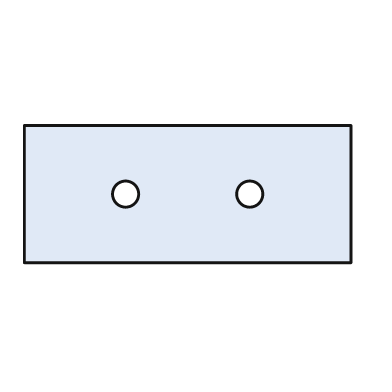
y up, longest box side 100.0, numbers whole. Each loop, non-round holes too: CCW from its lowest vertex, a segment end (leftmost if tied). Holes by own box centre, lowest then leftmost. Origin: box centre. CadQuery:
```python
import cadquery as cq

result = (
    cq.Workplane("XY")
    .moveTo(-50.0, -21.0)
    .lineTo(50.0, -21.0)
    .lineTo(50.0, 21.0)
    .lineTo(-50.0, 21.0)
    .close()
    .moveTo(-19.0, 0.0)
    .circle(4.0)
    .moveTo(19.0, 0.0)
    .circle(4.0)
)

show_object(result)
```